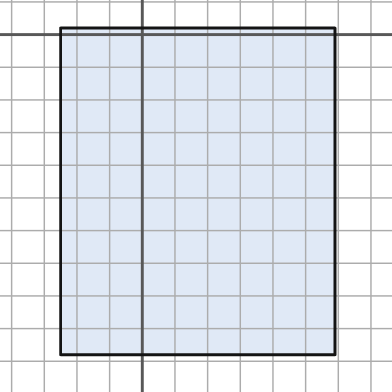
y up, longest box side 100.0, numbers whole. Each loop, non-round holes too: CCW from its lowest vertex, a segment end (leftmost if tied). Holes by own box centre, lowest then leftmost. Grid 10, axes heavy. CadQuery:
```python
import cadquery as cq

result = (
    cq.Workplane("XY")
    .moveTo(-25.0, -98.0)
    .lineTo(59.0, -98.0)
    .lineTo(59.0, 2.0)
    .lineTo(-25.0, 2.0)
    .close()
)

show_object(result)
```